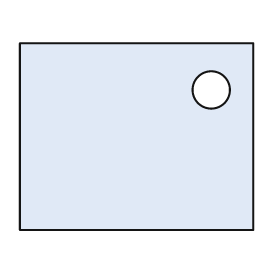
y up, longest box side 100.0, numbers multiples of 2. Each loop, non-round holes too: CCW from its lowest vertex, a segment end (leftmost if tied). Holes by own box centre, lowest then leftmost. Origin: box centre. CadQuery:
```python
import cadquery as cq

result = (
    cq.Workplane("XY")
    .moveTo(-50.0, -40.0)
    .lineTo(50.0, -40.0)
    .lineTo(50.0, 40.0)
    .lineTo(-50.0, 40.0)
    .close()
    .moveTo(32.0, 20.0)
    .circle(8.0)
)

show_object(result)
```